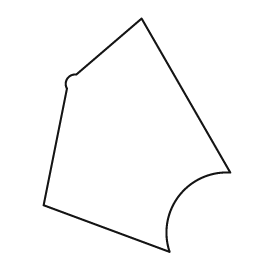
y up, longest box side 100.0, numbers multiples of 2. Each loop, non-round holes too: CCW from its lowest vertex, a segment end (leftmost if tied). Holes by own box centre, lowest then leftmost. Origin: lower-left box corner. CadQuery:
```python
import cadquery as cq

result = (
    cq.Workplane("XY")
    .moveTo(54.0, 0.0)
    .threePointArc((58.0, 24.0), (80.0, 34.0))
    .lineTo(42.0, 100.0)
    .lineTo(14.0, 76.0)
    .threePointArc((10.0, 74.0), (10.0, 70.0))
    .lineTo(0.0, 20.0)
    .close()
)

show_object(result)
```